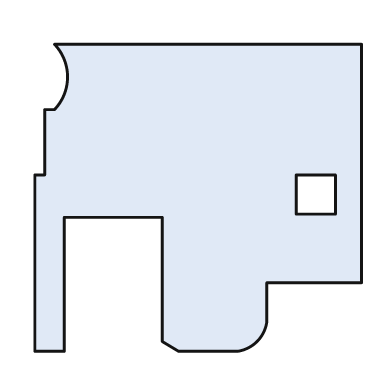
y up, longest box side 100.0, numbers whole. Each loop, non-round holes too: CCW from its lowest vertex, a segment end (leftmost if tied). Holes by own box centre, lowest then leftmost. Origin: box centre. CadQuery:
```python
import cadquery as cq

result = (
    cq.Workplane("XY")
    .moveTo(-50.0, -47.0)
    .lineTo(-41.0, -47.0)
    .lineTo(-41.0, -6.0)
    .lineTo(-11.0, -6.0)
    .lineTo(-11.0, -44.0)
    .lineTo(-6.0, -47.0)
    .lineTo(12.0, -47.0)
    .threePointArc((18.0, -44.0), (21.0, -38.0))
    .lineTo(21.0, -26.0)
    .lineTo(50.0, -26.0)
    .lineTo(50.0, 47.0)
    .lineTo(-44.0, 47.0)
    .threePointArc((-40.0, 37.0), (-44.0, 27.0))
    .lineTo(-47.0, 27.0)
    .lineTo(-47.0, 7.0)
    .lineTo(-50.0, 7.0)
    .close()
    .moveTo(30.0, -5.0)
    .lineTo(42.0, -5.0)
    .lineTo(42.0, 7.0)
    .lineTo(30.0, 7.0)
    .close()
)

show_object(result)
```